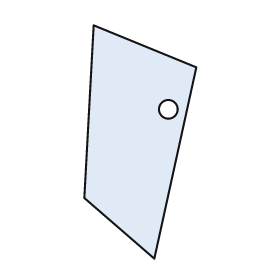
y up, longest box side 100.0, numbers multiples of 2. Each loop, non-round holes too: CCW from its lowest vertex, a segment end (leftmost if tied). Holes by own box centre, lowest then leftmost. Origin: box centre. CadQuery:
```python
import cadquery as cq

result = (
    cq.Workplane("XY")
    .moveTo(6.0, -50.0)
    .lineTo(24.0, 32.0)
    .lineTo(-20.0, 50.0)
    .lineTo(-24.0, -24.0)
    .close()
    .moveTo(12.0, 14.0)
    .circle(4.0)
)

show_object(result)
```